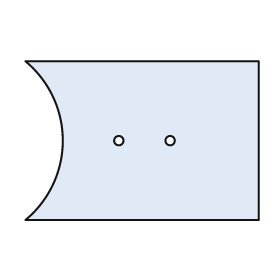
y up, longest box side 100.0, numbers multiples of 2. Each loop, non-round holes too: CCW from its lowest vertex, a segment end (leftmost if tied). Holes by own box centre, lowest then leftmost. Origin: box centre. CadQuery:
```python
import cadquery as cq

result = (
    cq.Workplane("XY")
    .moveTo(-50.0, -34.0)
    .lineTo(50.0, -34.0)
    .lineTo(50.0, 34.0)
    .lineTo(-50.0, 34.0)
    .threePointArc((-34.0, 0.0), (-50.0, -34.0))
    .close()
    .moveTo(-10.0, 0.0)
    .circle(2.0)
    .moveTo(12.0, 0.0)
    .circle(2.0)
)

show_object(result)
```